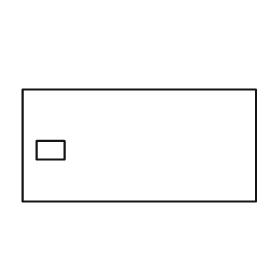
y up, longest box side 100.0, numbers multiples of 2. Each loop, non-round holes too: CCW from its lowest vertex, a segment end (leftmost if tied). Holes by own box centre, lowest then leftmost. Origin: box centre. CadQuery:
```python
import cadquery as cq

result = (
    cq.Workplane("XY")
    .moveTo(-50.0, -24.0)
    .lineTo(50.0, -24.0)
    .lineTo(50.0, 24.0)
    .lineTo(-50.0, 24.0)
    .close()
    .moveTo(-44.0, -6.0)
    .lineTo(-32.0, -6.0)
    .lineTo(-32.0, 2.0)
    .lineTo(-44.0, 2.0)
    .close()
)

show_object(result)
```